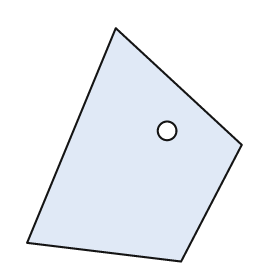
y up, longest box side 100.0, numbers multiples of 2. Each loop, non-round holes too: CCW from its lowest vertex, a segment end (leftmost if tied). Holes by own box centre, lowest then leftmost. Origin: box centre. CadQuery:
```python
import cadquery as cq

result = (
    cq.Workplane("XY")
    .moveTo(20.0, -50.0)
    .lineTo(46.0, 0.0)
    .lineTo(-8.0, 50.0)
    .lineTo(-46.0, -42.0)
    .close()
    .moveTo(14.0, 6.0)
    .circle(4.0)
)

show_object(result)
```